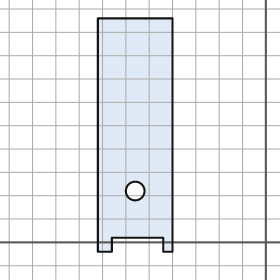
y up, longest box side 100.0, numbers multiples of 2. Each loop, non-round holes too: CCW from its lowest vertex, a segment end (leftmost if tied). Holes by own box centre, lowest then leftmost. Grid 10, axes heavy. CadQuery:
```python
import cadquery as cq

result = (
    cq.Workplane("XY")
    .moveTo(-72.0, -4.0)
    .lineTo(-66.0, -4.0)
    .lineTo(-66.0, 2.0)
    .lineTo(-44.0, 2.0)
    .lineTo(-44.0, -4.0)
    .lineTo(-40.0, -4.0)
    .lineTo(-40.0, 96.0)
    .lineTo(-72.0, 96.0)
    .close()
    .moveTo(-56.0, 22.0)
    .circle(4.0)
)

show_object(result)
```